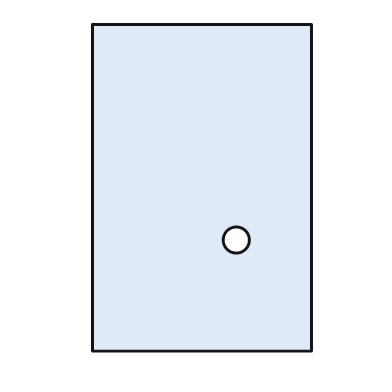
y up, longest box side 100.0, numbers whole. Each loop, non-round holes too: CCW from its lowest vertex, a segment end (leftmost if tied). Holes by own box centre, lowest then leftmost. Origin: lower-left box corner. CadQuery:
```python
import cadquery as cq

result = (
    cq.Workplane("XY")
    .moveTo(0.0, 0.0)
    .lineTo(67.0, 0.0)
    .lineTo(67.0, 100.0)
    .lineTo(0.0, 100.0)
    .close()
    .moveTo(44.0, 34.0)
    .circle(4.0)
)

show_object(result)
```